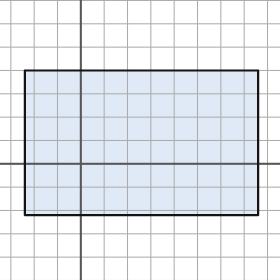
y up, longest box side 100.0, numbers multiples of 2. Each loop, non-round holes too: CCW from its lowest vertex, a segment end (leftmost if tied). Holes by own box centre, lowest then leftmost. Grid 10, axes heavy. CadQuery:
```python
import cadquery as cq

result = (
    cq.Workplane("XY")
    .moveTo(-24.0, -22.0)
    .lineTo(76.0, -22.0)
    .lineTo(76.0, 40.0)
    .lineTo(-24.0, 40.0)
    .close()
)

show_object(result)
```